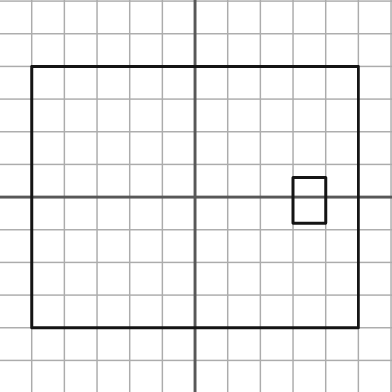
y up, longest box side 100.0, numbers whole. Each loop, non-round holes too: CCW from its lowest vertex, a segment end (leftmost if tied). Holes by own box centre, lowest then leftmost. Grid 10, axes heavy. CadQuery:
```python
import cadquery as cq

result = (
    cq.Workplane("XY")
    .moveTo(-50.0, -40.0)
    .lineTo(50.0, -40.0)
    .lineTo(50.0, 40.0)
    .lineTo(-50.0, 40.0)
    .close()
    .moveTo(30.0, -8.0)
    .lineTo(40.0, -8.0)
    .lineTo(40.0, 6.0)
    .lineTo(30.0, 6.0)
    .close()
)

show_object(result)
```